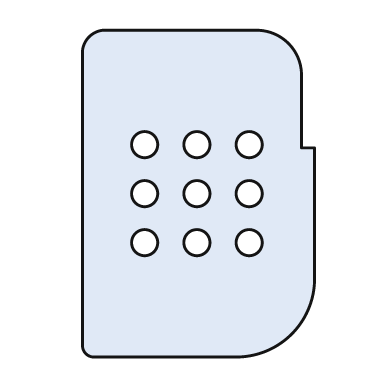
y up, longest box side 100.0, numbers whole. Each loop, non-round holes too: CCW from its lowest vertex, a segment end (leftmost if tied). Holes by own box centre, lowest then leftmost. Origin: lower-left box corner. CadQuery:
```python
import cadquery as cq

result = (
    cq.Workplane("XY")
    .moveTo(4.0, 0.0)
    .lineTo(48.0, 0.0)
    .threePointArc((64.0, 7.0), (71.0, 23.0))
    .lineTo(71.0, 64.0)
    .lineTo(67.0, 64.0)
    .lineTo(67.0, 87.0)
    .threePointArc((63.0, 96.0), (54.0, 100.0))
    .lineTo(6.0, 100.0)
    .threePointArc((2.0, 98.0), (0.0, 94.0))
    .lineTo(0.0, 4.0)
    .threePointArc((1.0, 1.0), (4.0, 0.0))
    .close()
    .moveTo(19.0, 35.0)
    .circle(4.0)
    .moveTo(35.0, 35.0)
    .circle(4.0)
    .moveTo(51.0, 35.0)
    .circle(4.0)
    .moveTo(19.0, 50.0)
    .circle(4.0)
    .moveTo(35.0, 50.0)
    .circle(4.0)
    .moveTo(51.0, 50.0)
    .circle(4.0)
    .moveTo(19.0, 65.0)
    .circle(4.0)
    .moveTo(35.0, 65.0)
    .circle(4.0)
    .moveTo(51.0, 65.0)
    .circle(4.0)
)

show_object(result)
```